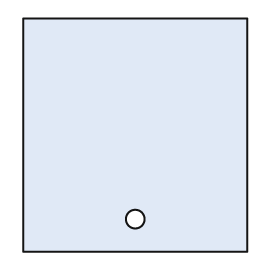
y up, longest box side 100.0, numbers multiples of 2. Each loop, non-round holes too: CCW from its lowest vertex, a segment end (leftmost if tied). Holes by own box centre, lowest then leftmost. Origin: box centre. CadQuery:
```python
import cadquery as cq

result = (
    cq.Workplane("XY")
    .moveTo(-48.0, -50.0)
    .lineTo(48.0, -50.0)
    .lineTo(48.0, 50.0)
    .lineTo(-48.0, 50.0)
    .close()
    .moveTo(0.0, -36.0)
    .circle(4.0)
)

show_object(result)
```